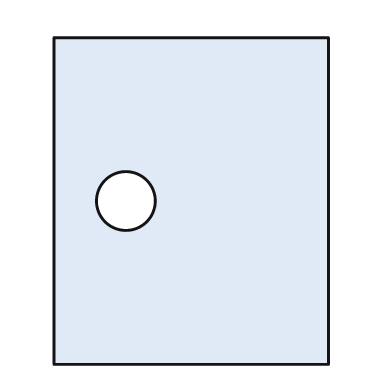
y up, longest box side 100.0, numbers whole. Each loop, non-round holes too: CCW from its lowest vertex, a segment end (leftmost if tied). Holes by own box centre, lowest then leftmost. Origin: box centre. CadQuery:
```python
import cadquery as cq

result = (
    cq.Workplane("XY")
    .moveTo(-42.0, -50.0)
    .lineTo(42.0, -50.0)
    .lineTo(42.0, 50.0)
    .lineTo(-42.0, 50.0)
    .close()
    .moveTo(-20.0, 0.0)
    .circle(9.0)
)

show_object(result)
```